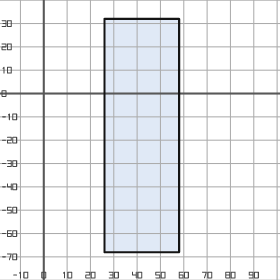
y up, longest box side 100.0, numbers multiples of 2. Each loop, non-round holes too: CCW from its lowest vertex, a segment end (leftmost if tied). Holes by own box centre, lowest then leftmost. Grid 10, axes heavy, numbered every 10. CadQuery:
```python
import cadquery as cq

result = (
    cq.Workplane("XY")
    .moveTo(26.0, -68.0)
    .lineTo(58.0, -68.0)
    .lineTo(58.0, 32.0)
    .lineTo(26.0, 32.0)
    .close()
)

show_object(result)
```